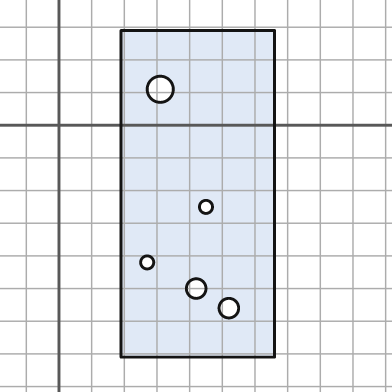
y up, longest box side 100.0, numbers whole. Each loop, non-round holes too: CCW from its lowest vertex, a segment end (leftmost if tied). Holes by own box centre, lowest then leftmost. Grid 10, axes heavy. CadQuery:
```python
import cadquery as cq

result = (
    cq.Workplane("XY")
    .moveTo(19.0, -71.0)
    .lineTo(66.0, -71.0)
    .lineTo(66.0, 29.0)
    .lineTo(19.0, 29.0)
    .close()
    .moveTo(52.0, -56.0)
    .circle(3.0)
    .moveTo(42.0, -50.0)
    .circle(3.0)
    .moveTo(27.0, -42.0)
    .circle(2.0)
    .moveTo(45.0, -25.0)
    .circle(2.0)
    .moveTo(31.0, 11.0)
    .circle(4.0)
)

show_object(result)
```